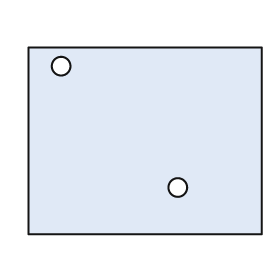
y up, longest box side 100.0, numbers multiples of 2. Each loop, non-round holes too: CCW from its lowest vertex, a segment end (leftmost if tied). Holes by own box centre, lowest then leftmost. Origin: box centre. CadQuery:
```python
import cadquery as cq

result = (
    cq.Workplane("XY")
    .moveTo(-50.0, -40.0)
    .lineTo(50.0, -40.0)
    .lineTo(50.0, 40.0)
    .lineTo(-50.0, 40.0)
    .close()
    .moveTo(14.0, -20.0)
    .circle(4.0)
    .moveTo(-36.0, 32.0)
    .circle(4.0)
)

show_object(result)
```